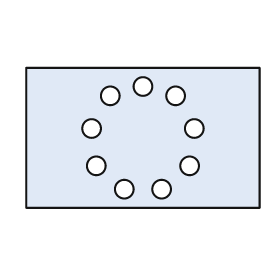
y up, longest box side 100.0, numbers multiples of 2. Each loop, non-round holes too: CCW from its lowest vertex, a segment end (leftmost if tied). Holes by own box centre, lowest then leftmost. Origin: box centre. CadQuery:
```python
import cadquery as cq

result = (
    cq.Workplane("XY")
    .moveTo(-50.0, -30.0)
    .lineTo(50.0, -30.0)
    .lineTo(50.0, 30.0)
    .lineTo(-50.0, 30.0)
    .close()
    .moveTo(-8.0, -22.0)
    .circle(4.0)
    .moveTo(8.0, -22.0)
    .circle(4.0)
    .moveTo(-20.0, -12.0)
    .circle(4.0)
    .moveTo(20.0, -12.0)
    .circle(4.0)
    .moveTo(-22.0, 4.0)
    .circle(4.0)
    .moveTo(22.0, 4.0)
    .circle(4.0)
    .moveTo(-14.0, 18.0)
    .circle(4.0)
    .moveTo(14.0, 18.0)
    .circle(4.0)
    .moveTo(0.0, 22.0)
    .circle(4.0)
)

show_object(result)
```